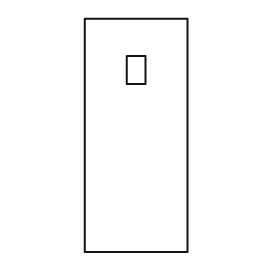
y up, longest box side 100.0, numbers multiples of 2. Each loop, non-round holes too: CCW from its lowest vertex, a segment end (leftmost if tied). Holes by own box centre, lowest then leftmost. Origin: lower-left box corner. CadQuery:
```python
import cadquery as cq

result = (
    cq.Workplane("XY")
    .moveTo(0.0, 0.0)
    .lineTo(44.0, 0.0)
    .lineTo(44.0, 100.0)
    .lineTo(0.0, 100.0)
    .close()
    .moveTo(18.0, 72.0)
    .lineTo(26.0, 72.0)
    .lineTo(26.0, 84.0)
    .lineTo(18.0, 84.0)
    .close()
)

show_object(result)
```